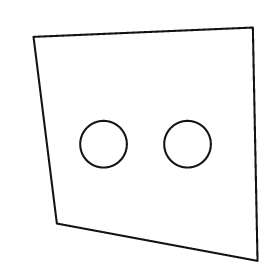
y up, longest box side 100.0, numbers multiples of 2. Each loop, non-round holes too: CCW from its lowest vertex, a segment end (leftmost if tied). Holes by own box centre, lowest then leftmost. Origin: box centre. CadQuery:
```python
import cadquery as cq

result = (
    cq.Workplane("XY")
    .moveTo(48.0, -50.0)
    .lineTo(46.0, 50.0)
    .lineTo(-48.0, 46.0)
    .lineTo(-38.0, -34.0)
    .close()
    .moveTo(-18.0, 0.0)
    .circle(10.0)
    .moveTo(18.0, 0.0)
    .circle(10.0)
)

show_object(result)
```